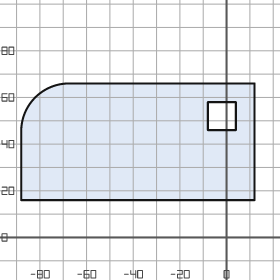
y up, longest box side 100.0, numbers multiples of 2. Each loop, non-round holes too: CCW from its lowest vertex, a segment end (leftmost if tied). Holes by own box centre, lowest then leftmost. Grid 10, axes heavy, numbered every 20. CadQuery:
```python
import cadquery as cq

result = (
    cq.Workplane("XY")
    .moveTo(-88.0, 16.0)
    .lineTo(12.0, 16.0)
    .lineTo(12.0, 66.0)
    .lineTo(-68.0, 66.0)
    .threePointArc((-82.0, 60.0), (-88.0, 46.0))
    .close()
    .moveTo(-8.0, 46.0)
    .lineTo(4.0, 46.0)
    .lineTo(4.0, 58.0)
    .lineTo(-8.0, 58.0)
    .close()
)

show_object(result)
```